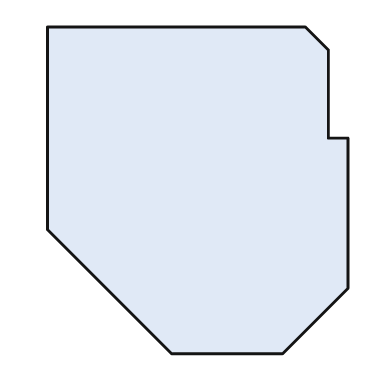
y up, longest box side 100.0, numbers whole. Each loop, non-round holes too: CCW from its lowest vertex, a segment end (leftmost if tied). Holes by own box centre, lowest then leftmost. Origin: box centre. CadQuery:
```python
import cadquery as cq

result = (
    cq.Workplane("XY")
    .moveTo(-8.0, -50.0)
    .lineTo(26.0, -50.0)
    .lineTo(46.0, -30.0)
    .lineTo(46.0, 16.0)
    .lineTo(40.0, 16.0)
    .lineTo(40.0, 43.0)
    .lineTo(33.0, 50.0)
    .lineTo(-46.0, 50.0)
    .lineTo(-46.0, -12.0)
    .close()
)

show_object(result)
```